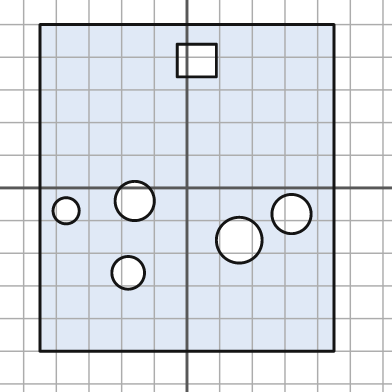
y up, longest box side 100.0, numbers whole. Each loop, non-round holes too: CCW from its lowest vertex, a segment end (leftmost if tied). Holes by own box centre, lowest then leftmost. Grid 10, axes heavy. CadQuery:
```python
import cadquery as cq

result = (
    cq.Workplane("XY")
    .moveTo(-45.0, -50.0)
    .lineTo(45.0, -50.0)
    .lineTo(45.0, 50.0)
    .lineTo(-45.0, 50.0)
    .close()
    .moveTo(-18.0, -26.0)
    .circle(5.0)
    .moveTo(16.0, -16.0)
    .circle(7.0)
    .moveTo(32.0, -8.0)
    .circle(6.0)
    .moveTo(-37.0, -7.0)
    .circle(4.0)
    .moveTo(-16.0, -4.0)
    .circle(6.0)
    .moveTo(-3.0, 34.0)
    .lineTo(9.0, 34.0)
    .lineTo(9.0, 44.0)
    .lineTo(-3.0, 44.0)
    .close()
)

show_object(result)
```